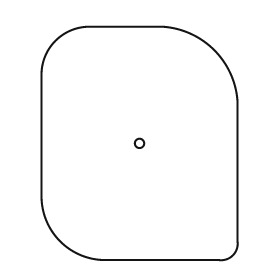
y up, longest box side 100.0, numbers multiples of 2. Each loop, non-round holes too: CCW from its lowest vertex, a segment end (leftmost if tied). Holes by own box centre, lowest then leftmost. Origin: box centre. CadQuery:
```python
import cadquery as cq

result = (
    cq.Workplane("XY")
    .moveTo(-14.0, -50.0)
    .lineTo(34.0, -50.0)
    .threePointArc((40.0, -48.0), (42.0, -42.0))
    .lineTo(42.0, 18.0)
    .threePointArc((32.0, 40.0), (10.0, 50.0))
    .lineTo(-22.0, 50.0)
    .threePointArc((-36.0, 44.0), (-42.0, 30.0))
    .lineTo(-42.0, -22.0)
    .threePointArc((-34.0, -42.0), (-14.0, -50.0))
    .close()
    .moveTo(0.0, 0.0)
    .circle(2.0)
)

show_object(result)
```